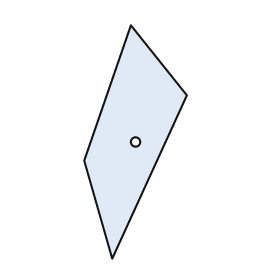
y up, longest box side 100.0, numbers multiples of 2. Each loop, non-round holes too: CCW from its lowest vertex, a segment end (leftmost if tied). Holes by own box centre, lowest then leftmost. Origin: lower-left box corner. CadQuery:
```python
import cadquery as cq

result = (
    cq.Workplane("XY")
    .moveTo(12.0, 0.0)
    .lineTo(44.0, 70.0)
    .lineTo(20.0, 100.0)
    .lineTo(0.0, 42.0)
    .close()
    .moveTo(22.0, 50.0)
    .circle(2.0)
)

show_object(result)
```